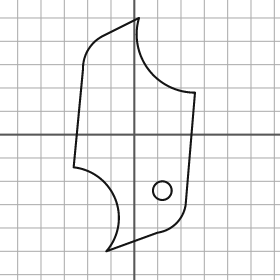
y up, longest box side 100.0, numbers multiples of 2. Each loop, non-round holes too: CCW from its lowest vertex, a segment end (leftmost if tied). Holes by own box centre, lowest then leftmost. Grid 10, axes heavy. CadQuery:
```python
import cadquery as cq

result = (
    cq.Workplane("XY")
    .moveTo(-12.0, -50.0)
    .lineTo(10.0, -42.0)
    .threePointArc((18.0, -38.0), (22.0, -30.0))
    .lineTo(26.0, 18.0)
    .threePointArc((6.0, 28.0), (2.0, 50.0))
    .lineTo(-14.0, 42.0)
    .threePointArc((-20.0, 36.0), (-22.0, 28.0))
    .lineTo(-26.0, -14.0)
    .threePointArc((-8.0, -28.0), (-12.0, -50.0))
    .close()
    .moveTo(12.0, -24.0)
    .circle(4.0)
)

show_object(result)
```